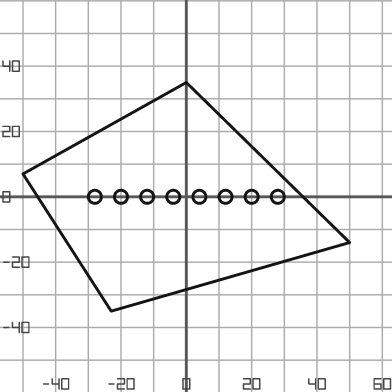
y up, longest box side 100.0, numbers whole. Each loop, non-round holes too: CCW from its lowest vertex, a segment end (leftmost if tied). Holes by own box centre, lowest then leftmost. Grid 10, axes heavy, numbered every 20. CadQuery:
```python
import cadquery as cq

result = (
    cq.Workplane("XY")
    .moveTo(-23.0, -35.0)
    .lineTo(50.0, -14.0)
    .lineTo(0.0, 35.0)
    .lineTo(-50.0, 7.0)
    .close()
    .moveTo(-28.0, 0.0)
    .circle(2.0)
    .moveTo(-20.0, 0.0)
    .circle(2.0)
    .moveTo(-12.0, 0.0)
    .circle(2.0)
    .moveTo(-4.0, 0.0)
    .circle(2.0)
    .moveTo(4.0, 0.0)
    .circle(2.0)
    .moveTo(12.0, 0.0)
    .circle(2.0)
    .moveTo(20.0, 0.0)
    .circle(2.0)
    .moveTo(28.0, 0.0)
    .circle(2.0)
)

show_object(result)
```